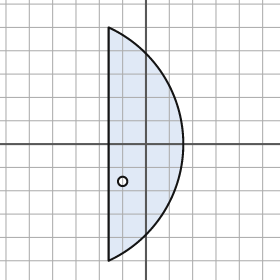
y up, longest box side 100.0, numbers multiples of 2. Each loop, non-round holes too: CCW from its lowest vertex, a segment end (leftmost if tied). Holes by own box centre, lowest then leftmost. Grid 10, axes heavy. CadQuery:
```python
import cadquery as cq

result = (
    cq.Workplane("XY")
    .moveTo(-16.0, -50.0)
    .threePointArc((16.0, 0.0), (-16.0, 50.0))
    .close()
    .moveTo(-10.0, -16.0)
    .circle(2.0)
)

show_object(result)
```